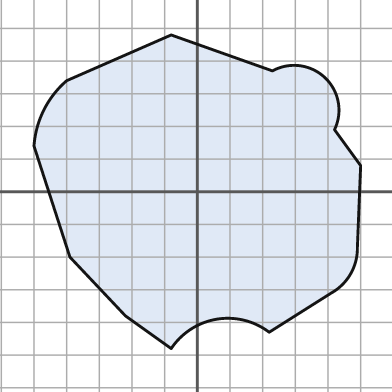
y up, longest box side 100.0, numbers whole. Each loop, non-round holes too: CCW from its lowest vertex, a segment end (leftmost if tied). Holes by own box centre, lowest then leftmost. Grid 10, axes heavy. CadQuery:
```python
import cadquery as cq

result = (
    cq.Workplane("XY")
    .moveTo(-8.0, -48.0)
    .threePointArc((6.0, -39.0), (22.0, -43.0))
    .lineTo(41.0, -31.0)
    .threePointArc((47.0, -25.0), (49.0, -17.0))
    .lineTo(50.0, 8.0)
    .lineTo(42.0, 19.0)
    .threePointArc((39.0, 35.0), (23.0, 37.0))
    .lineTo(-8.0, 48.0)
    .lineTo(-40.0, 34.0)
    .threePointArc((-47.0, 25.0), (-50.0, 14.0))
    .lineTo(-39.0, -20.0)
    .lineTo(-22.0, -38.0)
    .close()
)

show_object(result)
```